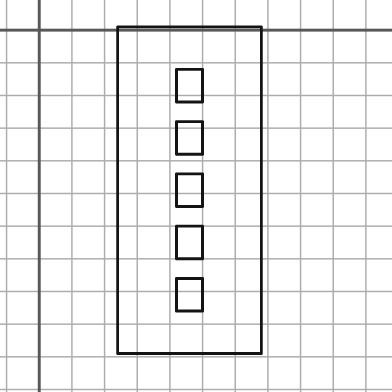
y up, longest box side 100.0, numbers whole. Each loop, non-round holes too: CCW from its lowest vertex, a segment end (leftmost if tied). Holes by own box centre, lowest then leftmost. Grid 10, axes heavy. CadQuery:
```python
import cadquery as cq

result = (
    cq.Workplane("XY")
    .moveTo(24.0, -99.0)
    .lineTo(68.0, -99.0)
    .lineTo(68.0, 1.0)
    .lineTo(24.0, 1.0)
    .close()
    .moveTo(42.0, -86.0)
    .lineTo(50.0, -86.0)
    .lineTo(50.0, -76.0)
    .lineTo(42.0, -76.0)
    .close()
    .moveTo(42.0, -70.0)
    .lineTo(50.0, -70.0)
    .lineTo(50.0, -60.0)
    .lineTo(42.0, -60.0)
    .close()
    .moveTo(42.0, -54.0)
    .lineTo(50.0, -54.0)
    .lineTo(50.0, -44.0)
    .lineTo(42.0, -44.0)
    .close()
    .moveTo(42.0, -38.0)
    .lineTo(50.0, -38.0)
    .lineTo(50.0, -28.0)
    .lineTo(42.0, -28.0)
    .close()
    .moveTo(42.0, -22.0)
    .lineTo(50.0, -22.0)
    .lineTo(50.0, -12.0)
    .lineTo(42.0, -12.0)
    .close()
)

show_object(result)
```